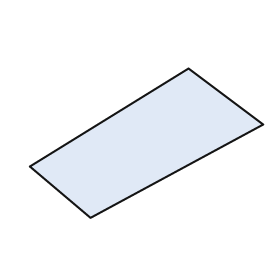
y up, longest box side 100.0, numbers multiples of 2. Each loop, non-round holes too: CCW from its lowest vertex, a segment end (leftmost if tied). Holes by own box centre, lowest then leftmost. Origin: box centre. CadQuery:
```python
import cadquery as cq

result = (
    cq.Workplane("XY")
    .moveTo(-24.0, -32.0)
    .lineTo(50.0, 8.0)
    .lineTo(18.0, 32.0)
    .lineTo(-50.0, -10.0)
    .close()
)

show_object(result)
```